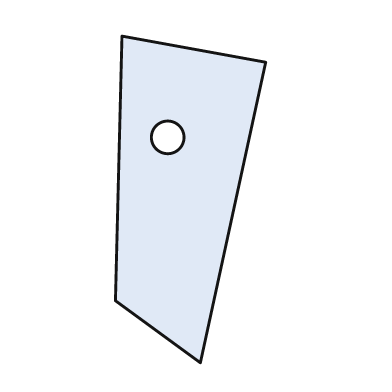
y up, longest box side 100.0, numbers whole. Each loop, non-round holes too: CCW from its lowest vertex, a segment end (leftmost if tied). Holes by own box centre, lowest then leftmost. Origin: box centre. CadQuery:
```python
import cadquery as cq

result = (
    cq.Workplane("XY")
    .moveTo(3.0, -50.0)
    .lineTo(23.0, 42.0)
    .lineTo(-21.0, 50.0)
    .lineTo(-23.0, -31.0)
    .close()
    .moveTo(-7.0, 19.0)
    .circle(5.0)
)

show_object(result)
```